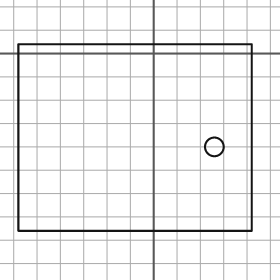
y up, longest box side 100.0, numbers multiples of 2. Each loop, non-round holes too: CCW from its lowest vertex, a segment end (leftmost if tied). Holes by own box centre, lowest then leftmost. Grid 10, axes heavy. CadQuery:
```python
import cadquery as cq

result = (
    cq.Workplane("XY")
    .moveTo(-58.0, -76.0)
    .lineTo(42.0, -76.0)
    .lineTo(42.0, 4.0)
    .lineTo(-58.0, 4.0)
    .close()
    .moveTo(26.0, -40.0)
    .circle(4.0)
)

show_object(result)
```